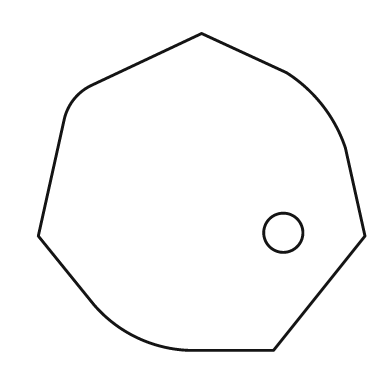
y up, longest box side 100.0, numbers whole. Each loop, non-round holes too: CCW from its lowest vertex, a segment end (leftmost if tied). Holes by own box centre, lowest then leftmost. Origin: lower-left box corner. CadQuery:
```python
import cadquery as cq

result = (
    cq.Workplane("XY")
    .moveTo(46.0, 0.0)
    .lineTo(72.0, 0.0)
    .lineTo(100.0, 35.0)
    .lineTo(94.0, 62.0)
    .threePointArc((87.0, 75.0), (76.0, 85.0))
    .lineTo(50.0, 97.0)
    .lineTo(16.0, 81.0)
    .threePointArc((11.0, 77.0), (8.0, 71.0))
    .lineTo(0.0, 35.0)
    .lineTo(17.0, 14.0)
    .threePointArc((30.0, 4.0), (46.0, 0.0))
    .close()
    .moveTo(75.0, 36.0)
    .circle(6.0)
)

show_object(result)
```